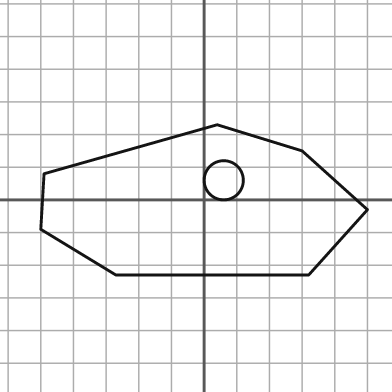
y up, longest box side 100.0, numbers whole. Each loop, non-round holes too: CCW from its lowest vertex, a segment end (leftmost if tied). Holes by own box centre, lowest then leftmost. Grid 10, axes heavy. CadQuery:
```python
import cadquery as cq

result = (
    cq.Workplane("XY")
    .moveTo(-27.0, -23.0)
    .lineTo(32.0, -23.0)
    .lineTo(50.0, -3.0)
    .lineTo(30.0, 15.0)
    .lineTo(4.0, 23.0)
    .lineTo(-49.0, 8.0)
    .lineTo(-50.0, -9.0)
    .close()
    .moveTo(6.0, 6.0)
    .circle(6.0)
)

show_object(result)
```